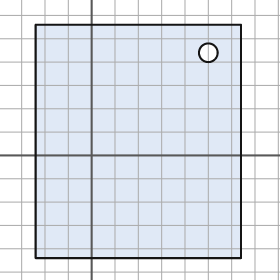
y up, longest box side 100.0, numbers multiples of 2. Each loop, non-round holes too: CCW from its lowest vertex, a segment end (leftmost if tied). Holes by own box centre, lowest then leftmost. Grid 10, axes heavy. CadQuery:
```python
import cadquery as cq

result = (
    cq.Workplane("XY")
    .moveTo(-24.0, -44.0)
    .lineTo(64.0, -44.0)
    .lineTo(64.0, 56.0)
    .lineTo(-24.0, 56.0)
    .close()
    .moveTo(50.0, 44.0)
    .circle(4.0)
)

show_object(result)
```